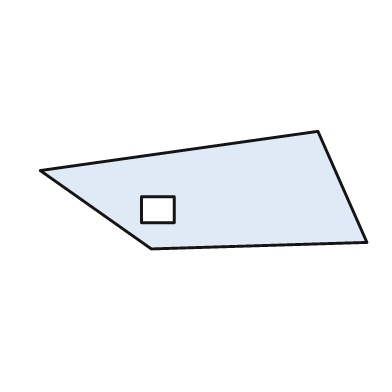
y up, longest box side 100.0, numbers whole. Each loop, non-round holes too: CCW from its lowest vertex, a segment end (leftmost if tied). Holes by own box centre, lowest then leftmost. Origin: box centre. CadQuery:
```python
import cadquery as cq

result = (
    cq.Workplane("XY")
    .moveTo(-16.0, -18.0)
    .lineTo(50.0, -16.0)
    .lineTo(35.0, 18.0)
    .lineTo(-50.0, 6.0)
    .close()
    .moveTo(-19.0, -10.0)
    .lineTo(-9.0, -10.0)
    .lineTo(-9.0, -2.0)
    .lineTo(-19.0, -2.0)
    .close()
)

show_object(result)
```